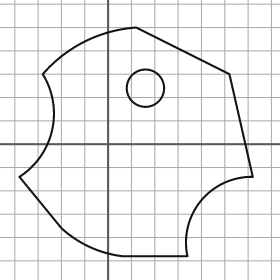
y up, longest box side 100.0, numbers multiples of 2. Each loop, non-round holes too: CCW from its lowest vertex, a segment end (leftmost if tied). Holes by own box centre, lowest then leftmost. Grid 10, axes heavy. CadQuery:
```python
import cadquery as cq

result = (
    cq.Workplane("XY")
    .moveTo(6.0, -48.0)
    .lineTo(34.0, -48.0)
    .threePointArc((40.0, -24.0), (62.0, -14.0))
    .lineTo(52.0, 30.0)
    .lineTo(12.0, 50.0)
    .threePointArc((-10.0, 44.0), (-28.0, 30.0))
    .threePointArc((-24.0, 6.0), (-38.0, -14.0))
    .lineTo(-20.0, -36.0)
    .threePointArc((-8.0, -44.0), (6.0, -48.0))
    .close()
    .moveTo(16.0, 24.0)
    .circle(8.0)
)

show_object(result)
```